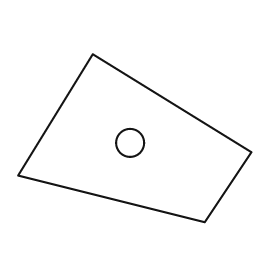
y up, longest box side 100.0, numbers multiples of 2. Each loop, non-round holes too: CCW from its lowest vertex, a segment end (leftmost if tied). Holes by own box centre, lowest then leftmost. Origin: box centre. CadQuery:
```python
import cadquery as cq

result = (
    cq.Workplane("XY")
    .moveTo(30.0, -36.0)
    .lineTo(50.0, -6.0)
    .lineTo(-18.0, 36.0)
    .lineTo(-50.0, -16.0)
    .close()
    .moveTo(-2.0, -2.0)
    .circle(6.0)
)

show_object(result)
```